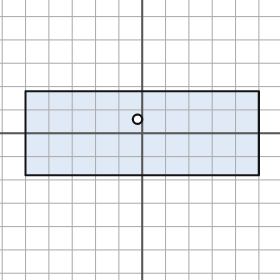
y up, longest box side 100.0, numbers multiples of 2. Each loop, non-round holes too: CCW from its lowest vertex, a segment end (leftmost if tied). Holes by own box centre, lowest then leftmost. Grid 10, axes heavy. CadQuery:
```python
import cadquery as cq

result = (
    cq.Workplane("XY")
    .moveTo(-50.0, -18.0)
    .lineTo(50.0, -18.0)
    .lineTo(50.0, 18.0)
    .lineTo(-50.0, 18.0)
    .close()
    .moveTo(-2.0, 6.0)
    .circle(2.0)
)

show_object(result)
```